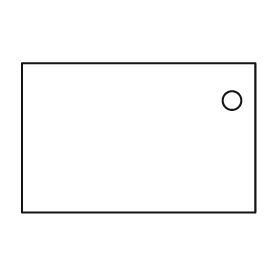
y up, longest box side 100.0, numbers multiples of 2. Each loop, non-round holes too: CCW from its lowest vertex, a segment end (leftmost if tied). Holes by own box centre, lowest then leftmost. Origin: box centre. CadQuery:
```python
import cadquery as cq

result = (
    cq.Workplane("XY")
    .moveTo(-50.0, -32.0)
    .lineTo(50.0, -32.0)
    .lineTo(50.0, 32.0)
    .lineTo(-50.0, 32.0)
    .close()
    .moveTo(40.0, 16.0)
    .circle(4.0)
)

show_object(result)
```